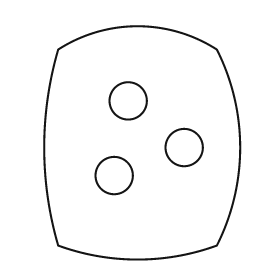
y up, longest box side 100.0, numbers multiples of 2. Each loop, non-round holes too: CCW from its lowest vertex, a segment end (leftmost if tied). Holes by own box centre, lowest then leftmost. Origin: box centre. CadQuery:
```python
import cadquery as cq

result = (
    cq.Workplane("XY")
    .moveTo(-36.0, -44.0)
    .threePointArc((-2.0, -50.0), (32.0, -44.0))
    .threePointArc((42.0, -2.0), (32.0, 40.0))
    .threePointArc((-2.0, 50.0), (-36.0, 40.0))
    .threePointArc((-42.0, -2.0), (-36.0, -44.0))
    .close()
    .moveTo(-12.0, -14.0)
    .circle(8.0)
    .moveTo(18.0, -2.0)
    .circle(8.0)
    .moveTo(-6.0, 18.0)
    .circle(8.0)
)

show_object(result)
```